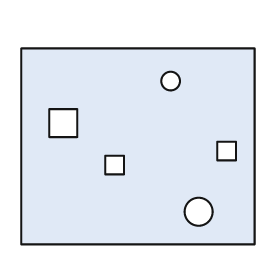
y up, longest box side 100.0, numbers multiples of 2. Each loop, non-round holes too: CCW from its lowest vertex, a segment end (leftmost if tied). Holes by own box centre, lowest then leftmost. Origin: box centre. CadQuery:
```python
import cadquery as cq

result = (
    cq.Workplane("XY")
    .moveTo(-50.0, -42.0)
    .lineTo(50.0, -42.0)
    .lineTo(50.0, 42.0)
    .lineTo(-50.0, 42.0)
    .close()
    .moveTo(26.0, -28.0)
    .circle(6.0)
    .moveTo(-14.0, -12.0)
    .lineTo(-6.0, -12.0)
    .lineTo(-6.0, -4.0)
    .lineTo(-14.0, -4.0)
    .close()
    .moveTo(34.0, -6.0)
    .lineTo(42.0, -6.0)
    .lineTo(42.0, 2.0)
    .lineTo(34.0, 2.0)
    .close()
    .moveTo(-38.0, 4.0)
    .lineTo(-26.0, 4.0)
    .lineTo(-26.0, 16.0)
    .lineTo(-38.0, 16.0)
    .close()
    .moveTo(14.0, 28.0)
    .circle(4.0)
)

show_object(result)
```